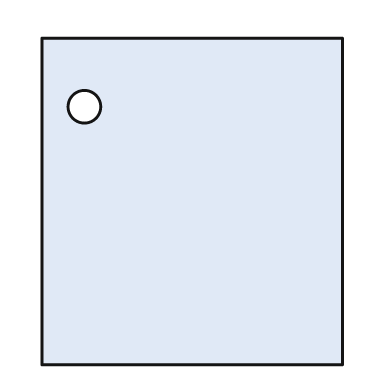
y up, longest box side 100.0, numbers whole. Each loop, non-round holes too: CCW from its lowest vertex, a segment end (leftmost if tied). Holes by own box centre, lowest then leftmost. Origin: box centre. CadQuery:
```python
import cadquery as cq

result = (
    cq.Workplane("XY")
    .moveTo(-46.0, -50.0)
    .lineTo(46.0, -50.0)
    .lineTo(46.0, 50.0)
    .lineTo(-46.0, 50.0)
    .close()
    .moveTo(-33.0, 29.0)
    .circle(5.0)
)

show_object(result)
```